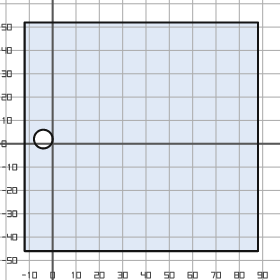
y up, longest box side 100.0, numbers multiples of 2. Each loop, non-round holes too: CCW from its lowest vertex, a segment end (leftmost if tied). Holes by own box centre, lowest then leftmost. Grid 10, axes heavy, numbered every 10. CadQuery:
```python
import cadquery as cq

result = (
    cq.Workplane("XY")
    .moveTo(-12.0, -46.0)
    .lineTo(88.0, -46.0)
    .lineTo(88.0, 52.0)
    .lineTo(-12.0, 52.0)
    .close()
    .moveTo(-4.0, 2.0)
    .circle(4.0)
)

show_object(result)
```